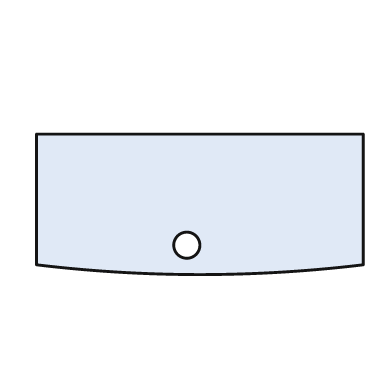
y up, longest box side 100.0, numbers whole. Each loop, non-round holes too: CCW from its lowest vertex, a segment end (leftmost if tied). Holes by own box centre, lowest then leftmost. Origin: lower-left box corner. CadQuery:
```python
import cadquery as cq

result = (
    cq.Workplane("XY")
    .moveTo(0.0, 3.0)
    .threePointArc((50.0, 0.0), (100.0, 3.0))
    .lineTo(100.0, 43.0)
    .lineTo(0.0, 43.0)
    .close()
    .moveTo(46.0, 9.0)
    .circle(4.0)
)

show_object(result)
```